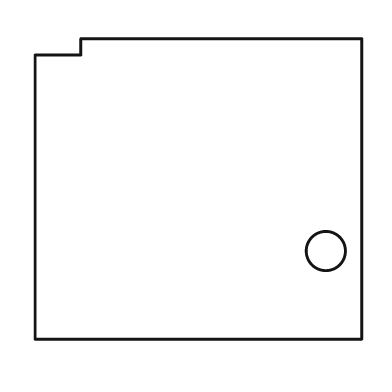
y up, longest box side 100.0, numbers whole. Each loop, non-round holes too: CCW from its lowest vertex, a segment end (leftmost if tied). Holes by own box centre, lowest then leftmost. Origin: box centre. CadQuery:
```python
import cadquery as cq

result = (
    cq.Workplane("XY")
    .moveTo(-50.0, -46.0)
    .lineTo(50.0, -46.0)
    .lineTo(50.0, 46.0)
    .lineTo(-36.0, 46.0)
    .lineTo(-36.0, 41.0)
    .lineTo(-50.0, 41.0)
    .close()
    .moveTo(39.0, -19.0)
    .circle(6.0)
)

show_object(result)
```